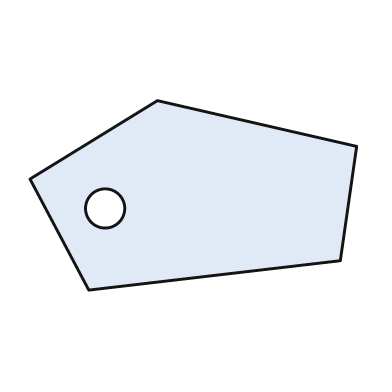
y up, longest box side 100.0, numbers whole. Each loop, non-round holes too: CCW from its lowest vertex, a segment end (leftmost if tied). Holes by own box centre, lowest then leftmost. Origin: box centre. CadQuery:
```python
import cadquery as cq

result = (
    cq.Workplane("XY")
    .moveTo(-32.0, -29.0)
    .lineTo(45.0, -20.0)
    .lineTo(50.0, 15.0)
    .lineTo(-11.0, 29.0)
    .lineTo(-50.0, 5.0)
    .close()
    .moveTo(-27.0, -4.0)
    .circle(6.0)
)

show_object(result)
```